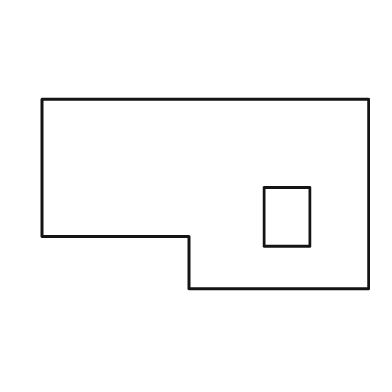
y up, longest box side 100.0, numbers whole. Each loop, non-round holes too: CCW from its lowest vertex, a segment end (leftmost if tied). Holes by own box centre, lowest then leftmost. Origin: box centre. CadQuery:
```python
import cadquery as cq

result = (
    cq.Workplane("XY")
    .moveTo(-5.0, -29.0)
    .lineTo(50.0, -29.0)
    .lineTo(50.0, 29.0)
    .lineTo(-50.0, 29.0)
    .lineTo(-50.0, -13.0)
    .lineTo(-5.0, -13.0)
    .close()
    .moveTo(18.0, -16.0)
    .lineTo(32.0, -16.0)
    .lineTo(32.0, 2.0)
    .lineTo(18.0, 2.0)
    .close()
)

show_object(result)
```